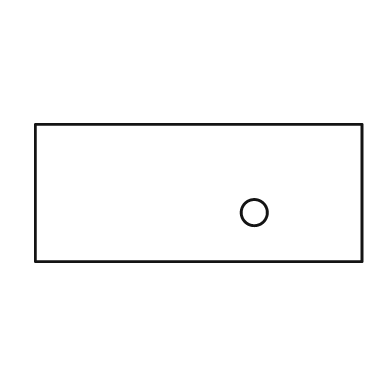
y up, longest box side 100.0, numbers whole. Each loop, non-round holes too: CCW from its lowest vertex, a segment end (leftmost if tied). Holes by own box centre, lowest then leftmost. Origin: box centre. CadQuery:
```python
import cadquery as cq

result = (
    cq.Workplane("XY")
    .moveTo(-50.0, -21.0)
    .lineTo(50.0, -21.0)
    .lineTo(50.0, 21.0)
    .lineTo(-50.0, 21.0)
    .close()
    .moveTo(17.0, -6.0)
    .circle(4.0)
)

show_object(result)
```